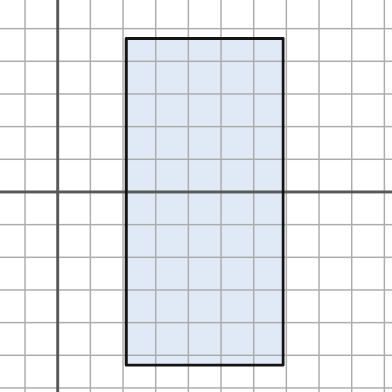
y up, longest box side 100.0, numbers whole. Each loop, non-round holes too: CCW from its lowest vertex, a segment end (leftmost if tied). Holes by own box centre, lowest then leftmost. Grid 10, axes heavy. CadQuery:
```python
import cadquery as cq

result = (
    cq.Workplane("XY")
    .moveTo(21.0, -53.0)
    .lineTo(69.0, -53.0)
    .lineTo(69.0, 47.0)
    .lineTo(21.0, 47.0)
    .close()
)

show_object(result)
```